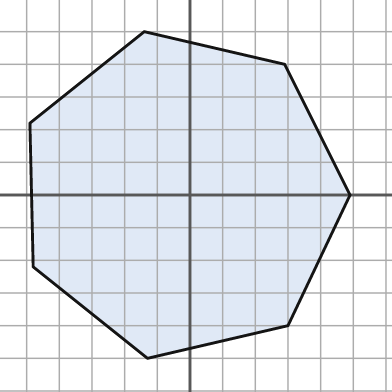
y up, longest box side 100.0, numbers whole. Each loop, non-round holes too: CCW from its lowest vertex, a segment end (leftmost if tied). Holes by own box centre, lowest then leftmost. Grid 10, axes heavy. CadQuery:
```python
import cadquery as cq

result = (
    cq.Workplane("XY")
    .moveTo(-13.0, -50.0)
    .lineTo(30.0, -40.0)
    .lineTo(49.0, 0.0)
    .lineTo(29.0, 40.0)
    .lineTo(-14.0, 50.0)
    .lineTo(-49.0, 22.0)
    .lineTo(-48.0, -22.0)
    .close()
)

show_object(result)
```